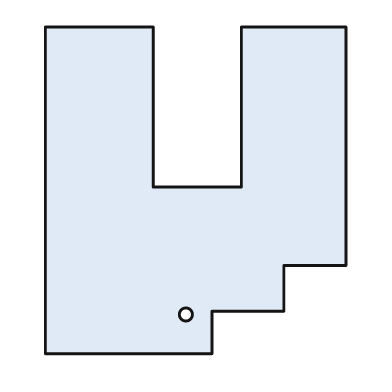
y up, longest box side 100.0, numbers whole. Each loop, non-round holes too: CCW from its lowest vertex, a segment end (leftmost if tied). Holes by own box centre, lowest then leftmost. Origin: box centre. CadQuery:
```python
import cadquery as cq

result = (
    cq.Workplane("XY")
    .moveTo(-46.0, -50.0)
    .lineTo(5.0, -50.0)
    .lineTo(5.0, -37.0)
    .lineTo(27.0, -37.0)
    .lineTo(27.0, -23.0)
    .lineTo(46.0, -23.0)
    .lineTo(46.0, 50.0)
    .lineTo(14.0, 50.0)
    .lineTo(14.0, 1.0)
    .lineTo(-13.0, 1.0)
    .lineTo(-13.0, 50.0)
    .lineTo(-46.0, 50.0)
    .close()
    .moveTo(-3.0, -38.0)
    .circle(2.0)
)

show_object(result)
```